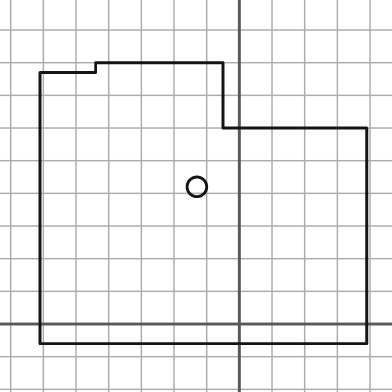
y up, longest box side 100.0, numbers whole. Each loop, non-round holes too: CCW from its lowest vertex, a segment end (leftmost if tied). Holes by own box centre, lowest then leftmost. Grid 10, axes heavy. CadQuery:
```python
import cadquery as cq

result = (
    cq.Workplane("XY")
    .moveTo(-61.0, -6.0)
    .lineTo(39.0, -6.0)
    .lineTo(39.0, 60.0)
    .lineTo(-5.0, 60.0)
    .lineTo(-5.0, 80.0)
    .lineTo(-44.0, 80.0)
    .lineTo(-44.0, 77.0)
    .lineTo(-61.0, 77.0)
    .close()
    .moveTo(-13.0, 42.0)
    .circle(3.0)
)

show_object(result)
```